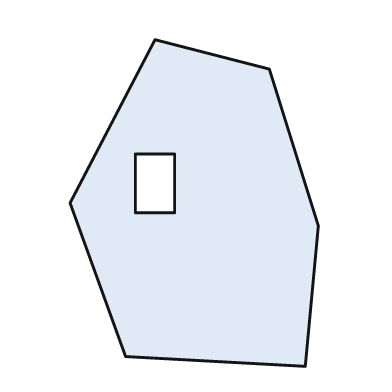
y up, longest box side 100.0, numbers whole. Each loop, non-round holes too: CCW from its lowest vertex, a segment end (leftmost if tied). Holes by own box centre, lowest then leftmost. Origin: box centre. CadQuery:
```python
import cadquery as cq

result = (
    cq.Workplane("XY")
    .moveTo(34.0, -50.0)
    .lineTo(38.0, -7.0)
    .lineTo(23.0, 41.0)
    .lineTo(-12.0, 50.0)
    .lineTo(-38.0, 0.0)
    .lineTo(-21.0, -47.0)
    .close()
    .moveTo(-18.0, -3.0)
    .lineTo(-6.0, -3.0)
    .lineTo(-6.0, 15.0)
    .lineTo(-18.0, 15.0)
    .close()
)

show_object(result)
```